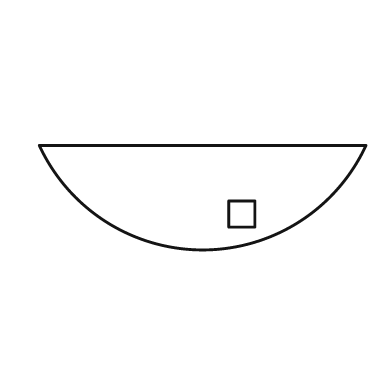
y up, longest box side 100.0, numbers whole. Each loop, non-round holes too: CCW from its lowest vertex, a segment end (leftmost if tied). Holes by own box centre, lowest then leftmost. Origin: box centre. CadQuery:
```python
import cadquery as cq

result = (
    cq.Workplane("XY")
    .moveTo(-50.0, 16.0)
    .threePointArc((0.0, -16.0), (50.0, 16.0))
    .close()
    .moveTo(8.0, -9.0)
    .lineTo(16.0, -9.0)
    .lineTo(16.0, -1.0)
    .lineTo(8.0, -1.0)
    .close()
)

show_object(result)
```